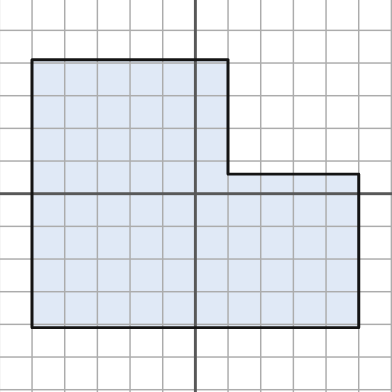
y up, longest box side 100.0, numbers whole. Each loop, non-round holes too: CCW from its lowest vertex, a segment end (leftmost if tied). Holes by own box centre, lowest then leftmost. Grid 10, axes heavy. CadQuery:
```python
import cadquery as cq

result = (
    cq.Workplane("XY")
    .moveTo(-50.0, -41.0)
    .lineTo(50.0, -41.0)
    .lineTo(50.0, 6.0)
    .lineTo(10.0, 6.0)
    .lineTo(10.0, 41.0)
    .lineTo(-50.0, 41.0)
    .close()
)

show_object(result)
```